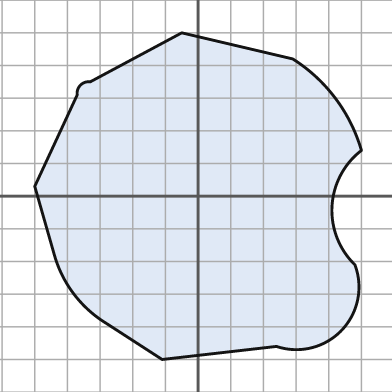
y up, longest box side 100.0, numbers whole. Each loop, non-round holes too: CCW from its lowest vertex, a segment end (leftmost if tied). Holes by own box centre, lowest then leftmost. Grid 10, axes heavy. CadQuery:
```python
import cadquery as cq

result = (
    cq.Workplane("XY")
    .moveTo(-11.0, -50.0)
    .lineTo(24.0, -46.0)
    .threePointArc((44.0, -41.0), (48.0, -21.0))
    .threePointArc((41.0, -3.0), (50.0, 14.0))
    .threePointArc((42.0, 30.0), (29.0, 42.0))
    .lineTo(-5.0, 50.0)
    .lineTo(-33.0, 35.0)
    .threePointArc((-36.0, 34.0), (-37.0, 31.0))
    .lineTo(-50.0, 3.0)
    .lineTo(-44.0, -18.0)
    .threePointArc((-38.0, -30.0), (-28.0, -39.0))
    .close()
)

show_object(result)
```